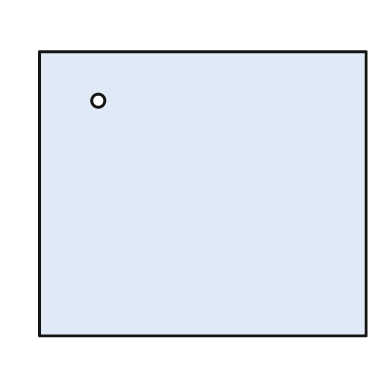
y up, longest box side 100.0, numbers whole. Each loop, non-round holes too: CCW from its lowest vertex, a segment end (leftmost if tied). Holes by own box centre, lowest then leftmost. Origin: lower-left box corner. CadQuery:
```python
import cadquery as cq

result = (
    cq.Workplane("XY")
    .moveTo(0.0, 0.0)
    .lineTo(100.0, 0.0)
    .lineTo(100.0, 87.0)
    .lineTo(0.0, 87.0)
    .close()
    .moveTo(18.0, 72.0)
    .circle(2.0)
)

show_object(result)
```